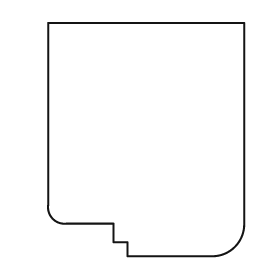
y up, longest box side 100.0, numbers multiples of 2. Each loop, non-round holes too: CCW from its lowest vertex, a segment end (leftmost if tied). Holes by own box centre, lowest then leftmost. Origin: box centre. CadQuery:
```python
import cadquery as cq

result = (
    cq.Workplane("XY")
    .moveTo(-8.0, -50.0)
    .lineTo(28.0, -50.0)
    .threePointArc((38.0, -46.0), (42.0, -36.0))
    .lineTo(42.0, 50.0)
    .lineTo(-42.0, 50.0)
    .lineTo(-42.0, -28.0)
    .threePointArc((-40.0, -34.0), (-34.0, -36.0))
    .lineTo(-14.0, -36.0)
    .lineTo(-14.0, -44.0)
    .lineTo(-8.0, -44.0)
    .close()
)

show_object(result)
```